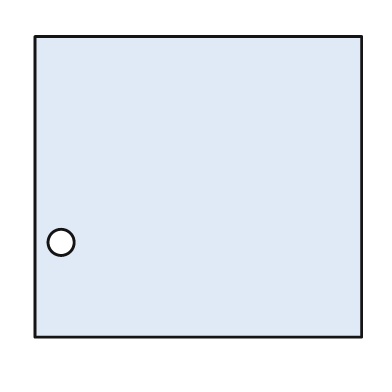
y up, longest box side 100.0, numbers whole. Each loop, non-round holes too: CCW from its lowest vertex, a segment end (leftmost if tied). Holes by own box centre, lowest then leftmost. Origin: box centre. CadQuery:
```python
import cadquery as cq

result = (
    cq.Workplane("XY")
    .moveTo(-50.0, -46.0)
    .lineTo(50.0, -46.0)
    .lineTo(50.0, 46.0)
    .lineTo(-50.0, 46.0)
    .close()
    .moveTo(-42.0, -17.0)
    .circle(4.0)
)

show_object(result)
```